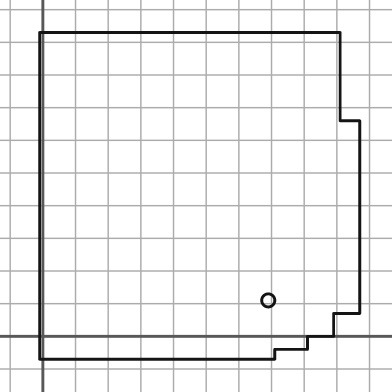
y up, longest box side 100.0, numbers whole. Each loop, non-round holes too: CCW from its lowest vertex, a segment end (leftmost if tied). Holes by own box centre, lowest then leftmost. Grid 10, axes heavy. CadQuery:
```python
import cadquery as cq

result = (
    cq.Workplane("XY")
    .moveTo(-1.0, -7.0)
    .lineTo(71.0, -7.0)
    .lineTo(71.0, -4.0)
    .lineTo(81.0, -4.0)
    .lineTo(81.0, 0.0)
    .lineTo(89.0, 0.0)
    .lineTo(89.0, 7.0)
    .lineTo(97.0, 7.0)
    .lineTo(97.0, 66.0)
    .lineTo(91.0, 66.0)
    .lineTo(91.0, 93.0)
    .lineTo(-1.0, 93.0)
    .close()
    .moveTo(69.0, 11.0)
    .circle(2.0)
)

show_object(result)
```